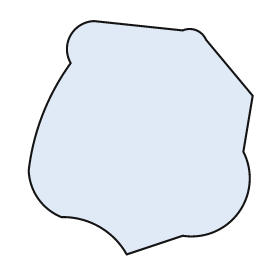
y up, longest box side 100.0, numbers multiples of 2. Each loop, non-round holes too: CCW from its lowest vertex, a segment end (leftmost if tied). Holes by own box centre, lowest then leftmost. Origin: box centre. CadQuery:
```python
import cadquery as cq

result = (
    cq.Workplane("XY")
    .moveTo(-6.0, -50.0)
    .lineTo(18.0, -42.0)
    .threePointArc((42.0, -32.0), (44.0, -6.0))
    .lineTo(48.0, 18.0)
    .lineTo(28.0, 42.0)
    .threePointArc((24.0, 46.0), (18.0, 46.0))
    .lineTo(-20.0, 50.0)
    .threePointArc((-30.0, 44.0), (-30.0, 32.0))
    .threePointArc((-42.0, 10.0), (-48.0, -14.0))
    .threePointArc((-44.0, -26.0), (-34.0, -34.0))
    .threePointArc((-18.0, -38.0), (-6.0, -50.0))
    .close()
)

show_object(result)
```